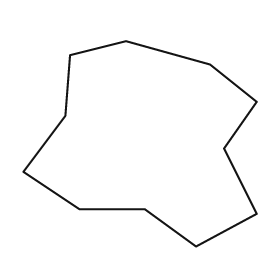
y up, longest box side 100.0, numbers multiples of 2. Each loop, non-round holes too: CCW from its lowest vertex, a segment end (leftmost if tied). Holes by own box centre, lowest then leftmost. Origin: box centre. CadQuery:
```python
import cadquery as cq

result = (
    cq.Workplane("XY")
    .moveTo(24.0, -44.0)
    .lineTo(50.0, -30.0)
    .lineTo(36.0, -2.0)
    .lineTo(50.0, 18.0)
    .lineTo(30.0, 34.0)
    .lineTo(-6.0, 44.0)
    .lineTo(-30.0, 38.0)
    .lineTo(-32.0, 12.0)
    .lineTo(-50.0, -12.0)
    .lineTo(-26.0, -28.0)
    .lineTo(2.0, -28.0)
    .close()
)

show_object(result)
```